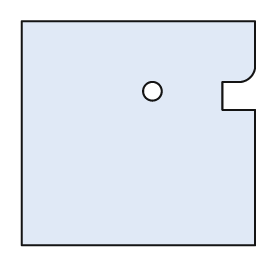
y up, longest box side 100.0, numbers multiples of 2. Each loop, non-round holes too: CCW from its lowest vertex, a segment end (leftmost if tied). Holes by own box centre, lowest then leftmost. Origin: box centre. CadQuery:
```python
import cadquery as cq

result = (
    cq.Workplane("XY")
    .moveTo(-50.0, -48.0)
    .lineTo(50.0, -48.0)
    .lineTo(50.0, 10.0)
    .lineTo(36.0, 10.0)
    .lineTo(36.0, 22.0)
    .lineTo(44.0, 22.0)
    .threePointArc((48.0, 24.0), (50.0, 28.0))
    .lineTo(50.0, 48.0)
    .lineTo(-50.0, 48.0)
    .close()
    .moveTo(6.0, 18.0)
    .circle(4.0)
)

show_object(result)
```